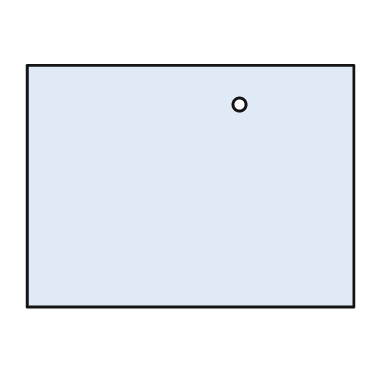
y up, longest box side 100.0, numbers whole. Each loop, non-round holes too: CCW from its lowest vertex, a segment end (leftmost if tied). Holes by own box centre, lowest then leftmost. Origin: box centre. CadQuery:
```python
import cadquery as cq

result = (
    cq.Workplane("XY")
    .moveTo(-50.0, -37.0)
    .lineTo(50.0, -37.0)
    .lineTo(50.0, 37.0)
    .lineTo(-50.0, 37.0)
    .close()
    .moveTo(15.0, 25.0)
    .circle(2.0)
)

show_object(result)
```